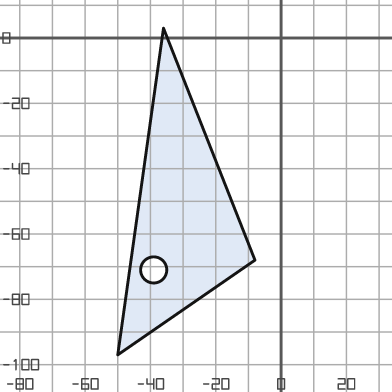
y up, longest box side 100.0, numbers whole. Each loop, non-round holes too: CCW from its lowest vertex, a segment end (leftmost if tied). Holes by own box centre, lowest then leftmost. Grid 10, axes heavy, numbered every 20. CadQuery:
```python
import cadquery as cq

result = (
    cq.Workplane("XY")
    .moveTo(-50.0, -97.0)
    .lineTo(-8.0, -68.0)
    .lineTo(-36.0, 3.0)
    .close()
    .moveTo(-39.0, -71.0)
    .circle(4.0)
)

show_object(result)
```